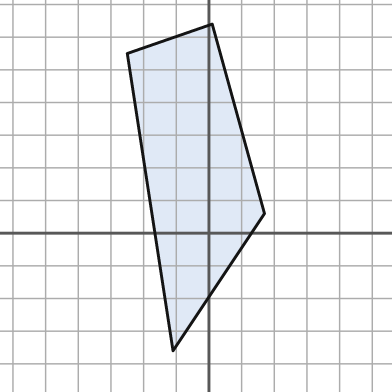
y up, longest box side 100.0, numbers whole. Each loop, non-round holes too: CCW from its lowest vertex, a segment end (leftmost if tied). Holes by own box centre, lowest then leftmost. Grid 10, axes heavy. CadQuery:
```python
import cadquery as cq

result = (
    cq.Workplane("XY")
    .moveTo(-11.0, -36.0)
    .lineTo(17.0, 6.0)
    .lineTo(1.0, 64.0)
    .lineTo(-25.0, 55.0)
    .close()
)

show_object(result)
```